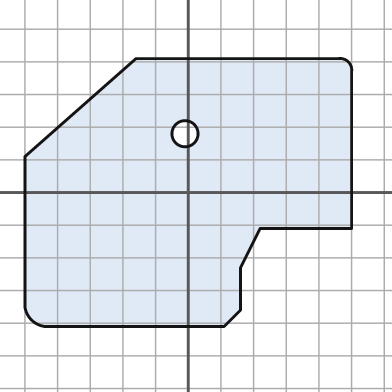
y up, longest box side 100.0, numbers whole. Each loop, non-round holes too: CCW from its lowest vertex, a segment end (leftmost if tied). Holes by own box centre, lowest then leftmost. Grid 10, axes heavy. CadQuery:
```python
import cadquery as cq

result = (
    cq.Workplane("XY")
    .moveTo(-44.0, -41.0)
    .lineTo(11.0, -41.0)
    .lineTo(16.0, -36.0)
    .lineTo(16.0, -23.0)
    .lineTo(22.0, -11.0)
    .lineTo(50.0, -11.0)
    .lineTo(50.0, 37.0)
    .threePointArc((49.0, 40.0), (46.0, 41.0))
    .lineTo(-16.0, 41.0)
    .lineTo(-50.0, 11.0)
    .lineTo(-50.0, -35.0)
    .threePointArc((-48.0, -39.0), (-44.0, -41.0))
    .close()
    .moveTo(-1.0, 18.0)
    .circle(4.0)
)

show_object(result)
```